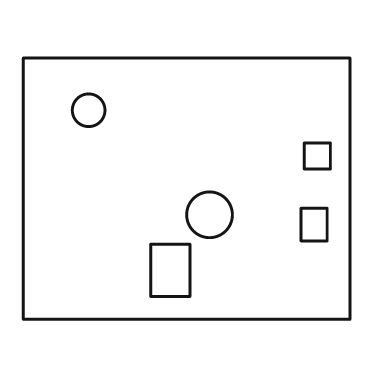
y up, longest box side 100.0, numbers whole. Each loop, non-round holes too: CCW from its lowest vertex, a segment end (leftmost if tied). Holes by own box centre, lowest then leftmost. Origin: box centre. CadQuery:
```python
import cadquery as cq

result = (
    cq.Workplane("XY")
    .moveTo(-50.0, -40.0)
    .lineTo(50.0, -40.0)
    .lineTo(50.0, 40.0)
    .lineTo(-50.0, 40.0)
    .close()
    .moveTo(-11.0, -33.0)
    .lineTo(1.0, -33.0)
    .lineTo(1.0, -17.0)
    .lineTo(-11.0, -17.0)
    .close()
    .moveTo(35.0, -16.0)
    .lineTo(43.0, -16.0)
    .lineTo(43.0, -6.0)
    .lineTo(35.0, -6.0)
    .close()
    .moveTo(7.0, -8.0)
    .circle(7.0)
    .moveTo(36.0, 6.0)
    .lineTo(44.0, 6.0)
    .lineTo(44.0, 14.0)
    .lineTo(36.0, 14.0)
    .close()
    .moveTo(-30.0, 24.0)
    .circle(5.0)
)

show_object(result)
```